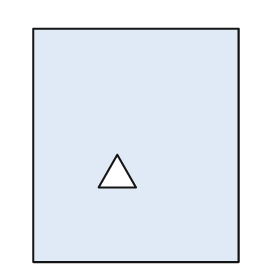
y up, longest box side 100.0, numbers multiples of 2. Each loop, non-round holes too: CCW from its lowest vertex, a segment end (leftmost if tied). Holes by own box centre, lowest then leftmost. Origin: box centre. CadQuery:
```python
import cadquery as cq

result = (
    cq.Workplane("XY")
    .moveTo(-44.0, -50.0)
    .lineTo(44.0, -50.0)
    .lineTo(44.0, 50.0)
    .lineTo(-44.0, 50.0)
    .close()
    .moveTo(-16.0, -18.0)
    .lineTo(0.0, -18.0)
    .lineTo(-8.0, -4.0)
    .close()
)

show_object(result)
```